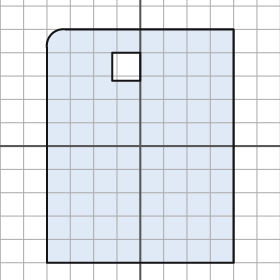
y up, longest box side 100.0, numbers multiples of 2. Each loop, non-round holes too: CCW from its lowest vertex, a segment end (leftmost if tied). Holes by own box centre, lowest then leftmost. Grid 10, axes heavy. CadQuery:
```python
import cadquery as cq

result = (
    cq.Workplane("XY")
    .moveTo(-40.0, -50.0)
    .lineTo(40.0, -50.0)
    .lineTo(40.0, 50.0)
    .lineTo(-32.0, 50.0)
    .threePointArc((-38.0, 48.0), (-40.0, 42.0))
    .close()
    .moveTo(-12.0, 28.0)
    .lineTo(0.0, 28.0)
    .lineTo(0.0, 40.0)
    .lineTo(-12.0, 40.0)
    .close()
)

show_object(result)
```